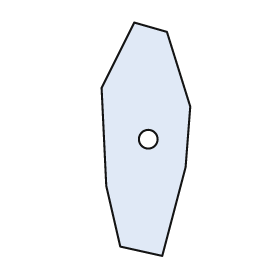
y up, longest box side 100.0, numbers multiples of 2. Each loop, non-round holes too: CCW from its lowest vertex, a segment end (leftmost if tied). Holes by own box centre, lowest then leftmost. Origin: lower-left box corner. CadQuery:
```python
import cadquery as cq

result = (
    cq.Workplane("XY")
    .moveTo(26.0, 0.0)
    .lineTo(36.0, 38.0)
    .lineTo(38.0, 64.0)
    .lineTo(28.0, 96.0)
    .lineTo(14.0, 100.0)
    .lineTo(0.0, 72.0)
    .lineTo(2.0, 30.0)
    .lineTo(8.0, 4.0)
    .close()
    .moveTo(20.0, 50.0)
    .circle(4.0)
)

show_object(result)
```